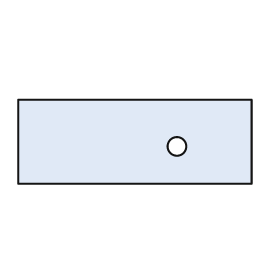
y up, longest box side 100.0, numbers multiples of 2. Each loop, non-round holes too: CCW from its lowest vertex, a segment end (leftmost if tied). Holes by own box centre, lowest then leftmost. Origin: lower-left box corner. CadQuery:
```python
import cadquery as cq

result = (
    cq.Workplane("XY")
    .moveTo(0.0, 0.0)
    .lineTo(100.0, 0.0)
    .lineTo(100.0, 36.0)
    .lineTo(0.0, 36.0)
    .close()
    .moveTo(68.0, 16.0)
    .circle(4.0)
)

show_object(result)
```